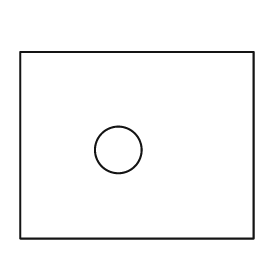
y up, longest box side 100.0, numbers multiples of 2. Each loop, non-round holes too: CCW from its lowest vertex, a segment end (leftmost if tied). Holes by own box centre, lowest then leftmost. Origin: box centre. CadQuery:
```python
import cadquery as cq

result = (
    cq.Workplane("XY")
    .moveTo(-50.0, -40.0)
    .lineTo(50.0, -40.0)
    .lineTo(50.0, 40.0)
    .lineTo(-50.0, 40.0)
    .close()
    .moveTo(-8.0, -2.0)
    .circle(10.0)
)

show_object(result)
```